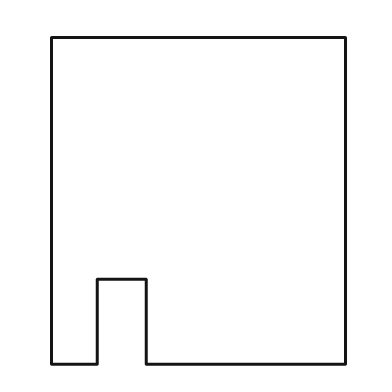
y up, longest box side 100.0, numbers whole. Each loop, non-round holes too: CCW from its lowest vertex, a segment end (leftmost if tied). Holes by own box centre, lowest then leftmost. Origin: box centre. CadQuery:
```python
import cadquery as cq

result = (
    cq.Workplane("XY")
    .moveTo(-45.0, -50.0)
    .lineTo(-31.0, -50.0)
    .lineTo(-31.0, -24.0)
    .lineTo(-16.0, -24.0)
    .lineTo(-16.0, -50.0)
    .lineTo(45.0, -50.0)
    .lineTo(45.0, 50.0)
    .lineTo(-45.0, 50.0)
    .close()
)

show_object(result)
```